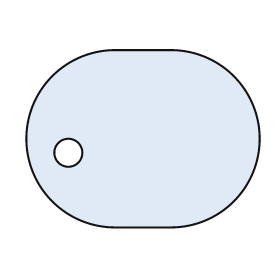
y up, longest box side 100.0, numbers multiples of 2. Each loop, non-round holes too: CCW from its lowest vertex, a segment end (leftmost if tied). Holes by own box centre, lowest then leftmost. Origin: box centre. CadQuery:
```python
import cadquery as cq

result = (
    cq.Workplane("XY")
    .moveTo(-12.0, -38.0)
    .lineTo(12.0, -38.0)
    .threePointArc((50.0, 0.0), (12.0, 38.0))
    .lineTo(-12.0, 38.0)
    .threePointArc((-50.0, 0.0), (-12.0, -38.0))
    .close()
    .moveTo(-32.0, -6.0)
    .circle(6.0)
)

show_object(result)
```